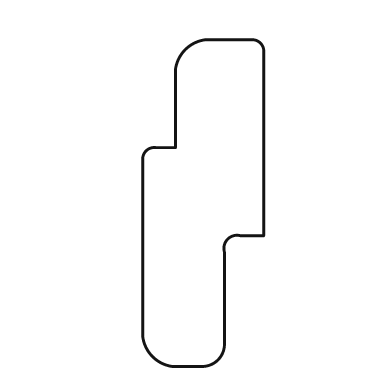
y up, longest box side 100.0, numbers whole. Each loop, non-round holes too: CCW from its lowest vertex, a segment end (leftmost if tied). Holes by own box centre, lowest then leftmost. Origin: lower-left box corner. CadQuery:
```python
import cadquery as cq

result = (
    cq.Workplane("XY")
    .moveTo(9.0, 0.0)
    .lineTo(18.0, 0.0)
    .threePointArc((23.0, 2.0), (25.0, 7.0))
    .lineTo(25.0, 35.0)
    .threePointArc((26.0, 39.0), (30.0, 40.0))
    .lineTo(37.0, 40.0)
    .lineTo(37.0, 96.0)
    .threePointArc((36.0, 99.0), (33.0, 100.0))
    .lineTo(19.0, 100.0)
    .threePointArc((13.0, 97.0), (10.0, 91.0))
    .lineTo(10.0, 67.0)
    .lineTo(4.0, 67.0)
    .threePointArc((1.0, 66.0), (0.0, 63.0))
    .lineTo(0.0, 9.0)
    .threePointArc((3.0, 3.0), (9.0, 0.0))
    .close()
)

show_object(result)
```